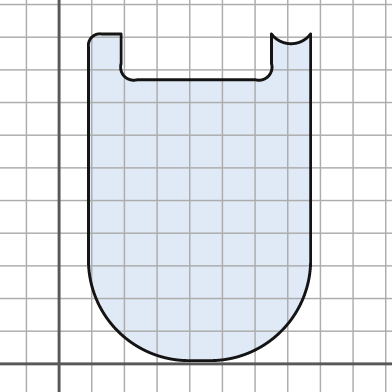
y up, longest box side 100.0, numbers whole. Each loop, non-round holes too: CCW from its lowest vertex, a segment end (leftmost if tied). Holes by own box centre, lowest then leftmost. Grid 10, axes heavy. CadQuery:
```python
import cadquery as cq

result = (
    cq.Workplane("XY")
    .moveTo(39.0, 1.0)
    .lineTo(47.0, 1.0)
    .threePointArc((68.0, 10.0), (77.0, 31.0))
    .lineTo(77.0, 101.0)
    .threePointArc((71.0, 98.0), (65.0, 101.0))
    .lineTo(65.0, 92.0)
    .threePointArc((64.0, 88.0), (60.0, 87.0))
    .lineTo(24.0, 87.0)
    .threePointArc((20.0, 88.0), (19.0, 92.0))
    .lineTo(19.0, 101.0)
    .lineTo(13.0, 101.0)
    .threePointArc((10.0, 100.0), (9.0, 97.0))
    .lineTo(9.0, 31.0)
    .threePointArc((18.0, 10.0), (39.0, 1.0))
    .close()
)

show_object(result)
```